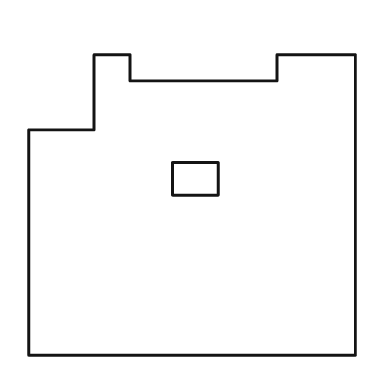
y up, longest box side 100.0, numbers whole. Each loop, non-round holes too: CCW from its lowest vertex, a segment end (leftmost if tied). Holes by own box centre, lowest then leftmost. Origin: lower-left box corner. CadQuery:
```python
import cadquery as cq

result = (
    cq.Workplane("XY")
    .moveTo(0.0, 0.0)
    .lineTo(100.0, 0.0)
    .lineTo(100.0, 92.0)
    .lineTo(76.0, 92.0)
    .lineTo(76.0, 84.0)
    .lineTo(31.0, 84.0)
    .lineTo(31.0, 92.0)
    .lineTo(20.0, 92.0)
    .lineTo(20.0, 69.0)
    .lineTo(0.0, 69.0)
    .close()
    .moveTo(44.0, 49.0)
    .lineTo(58.0, 49.0)
    .lineTo(58.0, 59.0)
    .lineTo(44.0, 59.0)
    .close()
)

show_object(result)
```